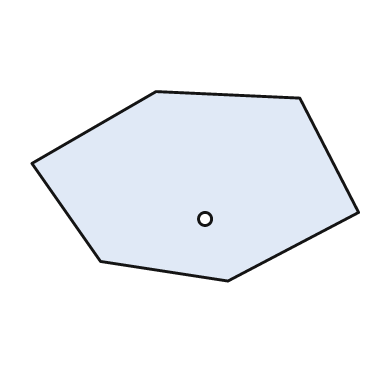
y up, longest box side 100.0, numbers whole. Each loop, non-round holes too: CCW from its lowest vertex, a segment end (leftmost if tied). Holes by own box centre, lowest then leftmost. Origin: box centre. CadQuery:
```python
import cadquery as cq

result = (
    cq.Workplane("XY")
    .moveTo(10.0, -29.0)
    .lineTo(50.0, -8.0)
    .lineTo(32.0, 27.0)
    .lineTo(-12.0, 29.0)
    .lineTo(-50.0, 7.0)
    .lineTo(-29.0, -23.0)
    .close()
    .moveTo(3.0, -10.0)
    .circle(2.0)
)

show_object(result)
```